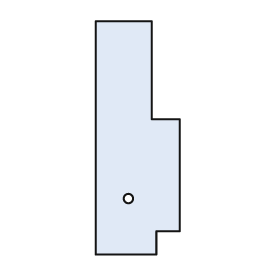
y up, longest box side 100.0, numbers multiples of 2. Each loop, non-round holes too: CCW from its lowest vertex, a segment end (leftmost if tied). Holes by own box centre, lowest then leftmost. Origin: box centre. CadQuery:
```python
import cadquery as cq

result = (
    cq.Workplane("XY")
    .moveTo(-18.0, -50.0)
    .lineTo(8.0, -50.0)
    .lineTo(8.0, -40.0)
    .lineTo(18.0, -40.0)
    .lineTo(18.0, 8.0)
    .lineTo(6.0, 8.0)
    .lineTo(6.0, 50.0)
    .lineTo(-18.0, 50.0)
    .close()
    .moveTo(-4.0, -26.0)
    .circle(2.0)
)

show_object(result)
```